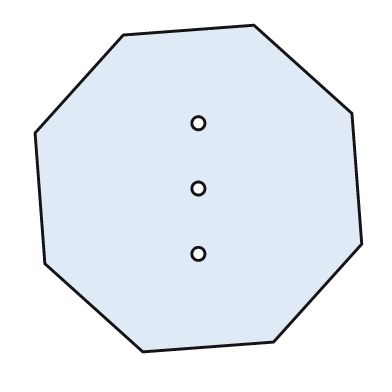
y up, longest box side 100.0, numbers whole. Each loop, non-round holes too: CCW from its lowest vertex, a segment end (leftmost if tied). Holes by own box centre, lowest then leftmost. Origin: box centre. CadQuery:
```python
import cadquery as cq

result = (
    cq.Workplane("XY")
    .moveTo(-17.0, -50.0)
    .lineTo(23.0, -47.0)
    .lineTo(50.0, -17.0)
    .lineTo(47.0, 23.0)
    .lineTo(17.0, 50.0)
    .lineTo(-23.0, 47.0)
    .lineTo(-50.0, 17.0)
    .lineTo(-47.0, -23.0)
    .close()
    .moveTo(0.0, -20.0)
    .circle(2.0)
    .moveTo(0.0, 0.0)
    .circle(2.0)
    .moveTo(0.0, 20.0)
    .circle(2.0)
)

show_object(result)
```